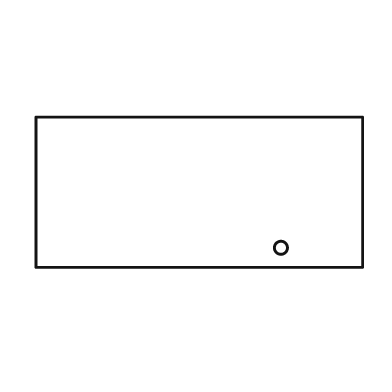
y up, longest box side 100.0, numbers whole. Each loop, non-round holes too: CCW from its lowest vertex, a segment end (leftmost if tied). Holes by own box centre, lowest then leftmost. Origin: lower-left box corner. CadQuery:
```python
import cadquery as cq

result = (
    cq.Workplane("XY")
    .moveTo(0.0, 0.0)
    .lineTo(100.0, 0.0)
    .lineTo(100.0, 46.0)
    .lineTo(0.0, 46.0)
    .close()
    .moveTo(75.0, 6.0)
    .circle(2.0)
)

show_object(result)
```